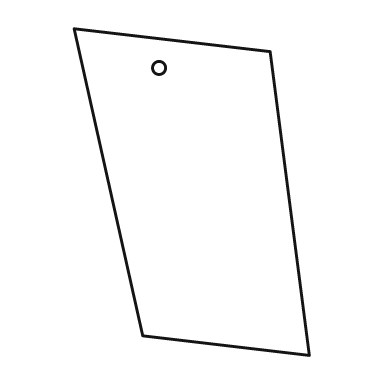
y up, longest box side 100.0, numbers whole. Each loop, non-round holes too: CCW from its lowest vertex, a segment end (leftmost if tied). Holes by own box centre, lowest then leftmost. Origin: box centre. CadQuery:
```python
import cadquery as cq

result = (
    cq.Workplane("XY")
    .moveTo(36.0, -50.0)
    .lineTo(24.0, 43.0)
    .lineTo(-36.0, 50.0)
    .lineTo(-15.0, -44.0)
    .close()
    .moveTo(-10.0, 38.0)
    .circle(2.0)
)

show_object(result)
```